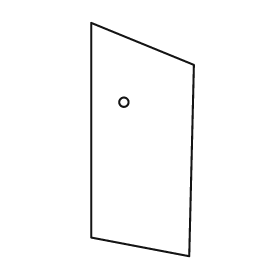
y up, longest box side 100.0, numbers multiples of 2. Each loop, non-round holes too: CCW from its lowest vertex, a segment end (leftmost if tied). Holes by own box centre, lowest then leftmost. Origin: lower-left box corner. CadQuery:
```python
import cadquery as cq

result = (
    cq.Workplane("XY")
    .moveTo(42.0, 0.0)
    .lineTo(44.0, 82.0)
    .lineTo(0.0, 100.0)
    .lineTo(0.0, 8.0)
    .close()
    .moveTo(14.0, 66.0)
    .circle(2.0)
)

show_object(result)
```